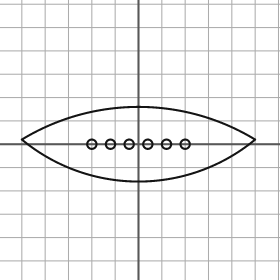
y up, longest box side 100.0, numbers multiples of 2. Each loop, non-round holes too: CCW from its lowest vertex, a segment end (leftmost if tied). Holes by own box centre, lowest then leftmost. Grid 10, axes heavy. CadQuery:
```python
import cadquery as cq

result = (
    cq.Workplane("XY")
    .moveTo(-50.0, 2.0)
    .threePointArc((0.0, -16.0), (50.0, 2.0))
    .threePointArc((0.0, 16.0), (-50.0, 2.0))
    .close()
    .moveTo(-20.0, 0.0)
    .circle(2.0)
    .moveTo(-12.0, 0.0)
    .circle(2.0)
    .moveTo(-4.0, 0.0)
    .circle(2.0)
    .moveTo(4.0, 0.0)
    .circle(2.0)
    .moveTo(12.0, 0.0)
    .circle(2.0)
    .moveTo(20.0, 0.0)
    .circle(2.0)
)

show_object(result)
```